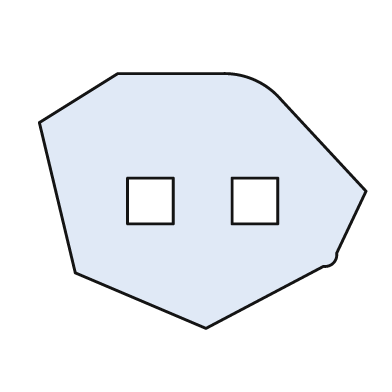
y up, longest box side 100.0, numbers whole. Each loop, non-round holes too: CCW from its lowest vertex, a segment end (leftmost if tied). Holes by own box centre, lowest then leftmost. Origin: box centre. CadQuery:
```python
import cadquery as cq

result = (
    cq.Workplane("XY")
    .moveTo(1.0, -39.0)
    .lineTo(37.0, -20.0)
    .threePointArc((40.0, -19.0), (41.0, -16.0))
    .lineTo(50.0, 3.0)
    .lineTo(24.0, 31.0)
    .threePointArc((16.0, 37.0), (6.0, 39.0))
    .lineTo(-26.0, 39.0)
    .lineTo(-50.0, 24.0)
    .lineTo(-39.0, -22.0)
    .close()
    .moveTo(-23.0, -7.0)
    .lineTo(-9.0, -7.0)
    .lineTo(-9.0, 7.0)
    .lineTo(-23.0, 7.0)
    .close()
    .moveTo(9.0, -7.0)
    .lineTo(23.0, -7.0)
    .lineTo(23.0, 7.0)
    .lineTo(9.0, 7.0)
    .close()
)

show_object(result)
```